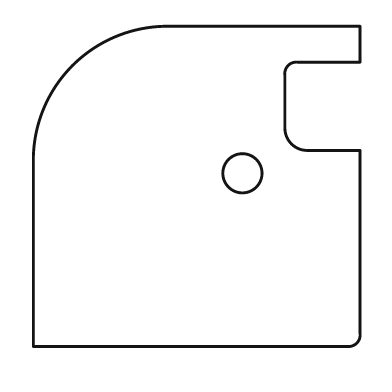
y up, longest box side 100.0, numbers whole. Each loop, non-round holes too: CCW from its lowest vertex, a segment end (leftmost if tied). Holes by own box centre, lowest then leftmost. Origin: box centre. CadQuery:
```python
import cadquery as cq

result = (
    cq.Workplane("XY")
    .moveTo(-50.0, -49.0)
    .lineTo(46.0, -49.0)
    .threePointArc((49.0, -48.0), (50.0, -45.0))
    .lineTo(50.0, 11.0)
    .lineTo(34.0, 11.0)
    .threePointArc((29.0, 13.0), (27.0, 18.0))
    .lineTo(27.0, 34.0)
    .threePointArc((28.0, 37.0), (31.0, 38.0))
    .lineTo(50.0, 38.0)
    .lineTo(50.0, 49.0)
    .lineTo(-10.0, 49.0)
    .threePointArc((-38.0, 37.0), (-50.0, 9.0))
    .close()
    .moveTo(14.0, 4.0)
    .circle(6.0)
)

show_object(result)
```